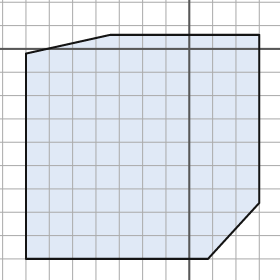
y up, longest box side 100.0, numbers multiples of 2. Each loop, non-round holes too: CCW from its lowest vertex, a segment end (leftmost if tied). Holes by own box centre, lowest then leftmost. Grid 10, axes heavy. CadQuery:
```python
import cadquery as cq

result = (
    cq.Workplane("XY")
    .moveTo(-70.0, -90.0)
    .lineTo(8.0, -90.0)
    .lineTo(30.0, -66.0)
    .lineTo(30.0, 6.0)
    .lineTo(-34.0, 6.0)
    .lineTo(-70.0, -2.0)
    .close()
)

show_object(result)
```